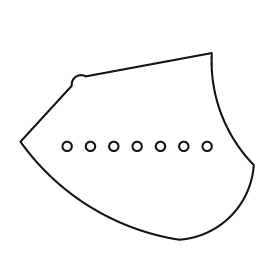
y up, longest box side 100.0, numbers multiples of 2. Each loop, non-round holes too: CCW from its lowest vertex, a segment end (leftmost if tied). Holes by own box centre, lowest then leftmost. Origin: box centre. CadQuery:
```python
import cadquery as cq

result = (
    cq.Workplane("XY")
    .moveTo(18.0, -40.0)
    .threePointArc((40.0, -30.0), (50.0, -8.0))
    .threePointArc((36.0, 14.0), (32.0, 40.0))
    .lineTo(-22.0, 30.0)
    .threePointArc((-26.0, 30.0), (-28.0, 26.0))
    .lineTo(-50.0, 2.0)
    .threePointArc((-20.0, -26.0), (18.0, -40.0))
    .close()
    .moveTo(-30.0, 0.0)
    .circle(2.0)
    .moveTo(-20.0, 0.0)
    .circle(2.0)
    .moveTo(-10.0, 0.0)
    .circle(2.0)
    .moveTo(0.0, 0.0)
    .circle(2.0)
    .moveTo(10.0, 0.0)
    .circle(2.0)
    .moveTo(20.0, 0.0)
    .circle(2.0)
    .moveTo(30.0, 0.0)
    .circle(2.0)
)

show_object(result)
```